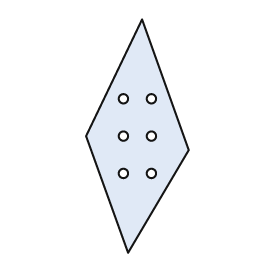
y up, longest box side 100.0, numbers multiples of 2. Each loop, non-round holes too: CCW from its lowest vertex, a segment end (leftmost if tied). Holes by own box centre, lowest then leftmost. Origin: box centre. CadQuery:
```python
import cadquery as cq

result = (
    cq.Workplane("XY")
    .moveTo(-4.0, -50.0)
    .lineTo(22.0, -6.0)
    .lineTo(2.0, 50.0)
    .lineTo(-22.0, 0.0)
    .close()
    .moveTo(-6.0, -16.0)
    .circle(2.0)
    .moveTo(6.0, -16.0)
    .circle(2.0)
    .moveTo(-6.0, 0.0)
    .circle(2.0)
    .moveTo(6.0, 0.0)
    .circle(2.0)
    .moveTo(-6.0, 16.0)
    .circle(2.0)
    .moveTo(6.0, 16.0)
    .circle(2.0)
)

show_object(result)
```